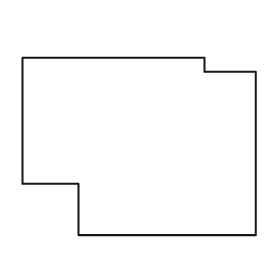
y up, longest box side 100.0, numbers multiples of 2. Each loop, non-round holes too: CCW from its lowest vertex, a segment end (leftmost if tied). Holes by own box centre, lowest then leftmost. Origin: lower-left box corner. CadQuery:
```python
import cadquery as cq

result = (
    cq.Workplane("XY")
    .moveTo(24.0, 0.0)
    .lineTo(100.0, 0.0)
    .lineTo(100.0, 70.0)
    .lineTo(78.0, 70.0)
    .lineTo(78.0, 76.0)
    .lineTo(0.0, 76.0)
    .lineTo(0.0, 22.0)
    .lineTo(24.0, 22.0)
    .close()
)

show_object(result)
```